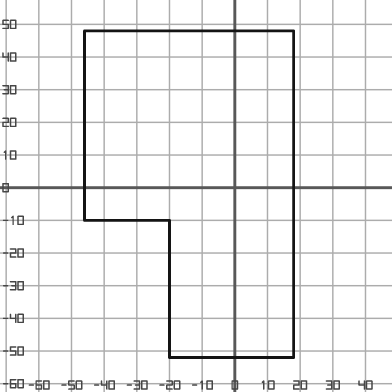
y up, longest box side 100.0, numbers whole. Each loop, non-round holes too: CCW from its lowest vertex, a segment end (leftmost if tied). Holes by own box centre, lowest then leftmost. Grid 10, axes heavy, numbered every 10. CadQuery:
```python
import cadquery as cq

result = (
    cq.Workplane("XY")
    .moveTo(-20.0, -52.0)
    .lineTo(18.0, -52.0)
    .lineTo(18.0, 48.0)
    .lineTo(-46.0, 48.0)
    .lineTo(-46.0, -10.0)
    .lineTo(-20.0, -10.0)
    .close()
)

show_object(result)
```